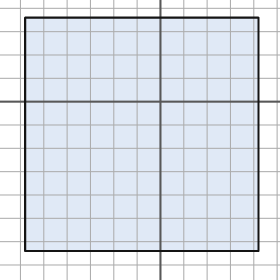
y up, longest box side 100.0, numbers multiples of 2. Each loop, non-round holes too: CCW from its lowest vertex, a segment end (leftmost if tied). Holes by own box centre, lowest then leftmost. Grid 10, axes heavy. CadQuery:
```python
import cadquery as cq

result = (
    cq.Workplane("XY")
    .moveTo(-58.0, -64.0)
    .lineTo(42.0, -64.0)
    .lineTo(42.0, 36.0)
    .lineTo(-58.0, 36.0)
    .close()
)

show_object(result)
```